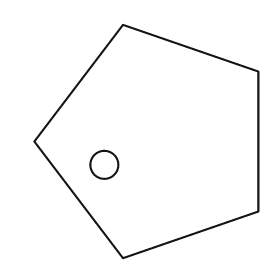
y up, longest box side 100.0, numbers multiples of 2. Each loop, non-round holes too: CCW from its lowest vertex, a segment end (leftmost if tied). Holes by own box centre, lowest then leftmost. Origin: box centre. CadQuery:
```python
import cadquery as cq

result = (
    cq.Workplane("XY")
    .moveTo(-10.0, -50.0)
    .lineTo(48.0, -30.0)
    .lineTo(48.0, 30.0)
    .lineTo(-10.0, 50.0)
    .lineTo(-48.0, 0.0)
    .close()
    .moveTo(-18.0, -10.0)
    .circle(6.0)
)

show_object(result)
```